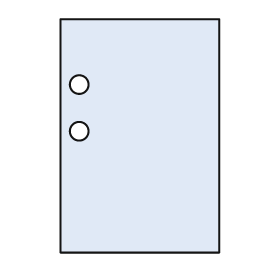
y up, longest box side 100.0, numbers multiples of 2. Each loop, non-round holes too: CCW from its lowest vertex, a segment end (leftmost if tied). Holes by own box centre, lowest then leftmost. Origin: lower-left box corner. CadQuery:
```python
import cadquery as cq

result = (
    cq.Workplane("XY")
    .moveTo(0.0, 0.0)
    .lineTo(68.0, 0.0)
    .lineTo(68.0, 100.0)
    .lineTo(0.0, 100.0)
    .close()
    .moveTo(8.0, 52.0)
    .circle(4.0)
    .moveTo(8.0, 72.0)
    .circle(4.0)
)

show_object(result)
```